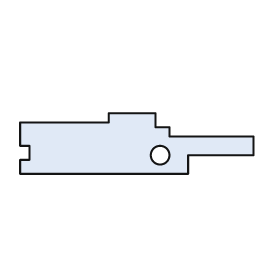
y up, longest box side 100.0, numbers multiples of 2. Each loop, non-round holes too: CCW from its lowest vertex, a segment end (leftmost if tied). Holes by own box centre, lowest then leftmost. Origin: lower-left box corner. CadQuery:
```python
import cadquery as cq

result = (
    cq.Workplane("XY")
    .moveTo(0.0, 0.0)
    .lineTo(72.0, 0.0)
    .lineTo(72.0, 8.0)
    .lineTo(100.0, 8.0)
    .lineTo(100.0, 16.0)
    .lineTo(64.0, 16.0)
    .lineTo(64.0, 20.0)
    .lineTo(58.0, 20.0)
    .lineTo(58.0, 26.0)
    .lineTo(38.0, 26.0)
    .lineTo(38.0, 22.0)
    .lineTo(0.0, 22.0)
    .lineTo(0.0, 12.0)
    .lineTo(4.0, 12.0)
    .lineTo(4.0, 6.0)
    .lineTo(0.0, 6.0)
    .close()
    .moveTo(60.0, 8.0)
    .circle(4.0)
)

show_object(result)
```